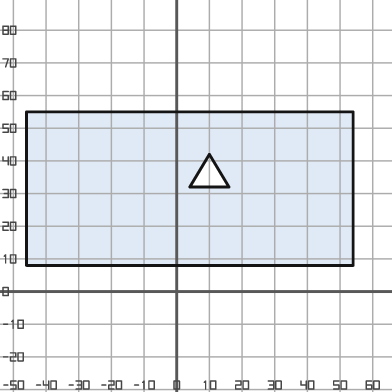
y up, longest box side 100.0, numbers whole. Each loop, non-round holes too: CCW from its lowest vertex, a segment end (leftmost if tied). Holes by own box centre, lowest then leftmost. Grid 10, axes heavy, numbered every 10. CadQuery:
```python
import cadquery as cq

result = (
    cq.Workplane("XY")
    .moveTo(-46.0, 8.0)
    .lineTo(54.0, 8.0)
    .lineTo(54.0, 55.0)
    .lineTo(-46.0, 55.0)
    .close()
    .moveTo(4.0, 32.0)
    .lineTo(16.0, 32.0)
    .lineTo(10.0, 42.0)
    .close()
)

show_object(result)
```